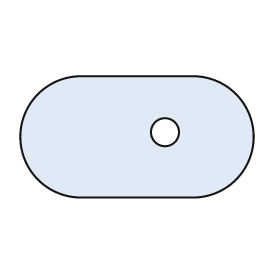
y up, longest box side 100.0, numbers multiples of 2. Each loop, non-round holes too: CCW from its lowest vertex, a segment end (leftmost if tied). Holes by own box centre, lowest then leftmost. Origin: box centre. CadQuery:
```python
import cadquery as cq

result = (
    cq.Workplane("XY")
    .moveTo(-24.0, -26.0)
    .lineTo(24.0, -26.0)
    .threePointArc((50.0, 0.0), (24.0, 26.0))
    .lineTo(-24.0, 26.0)
    .threePointArc((-50.0, 0.0), (-24.0, -26.0))
    .close()
    .moveTo(12.0, 2.0)
    .circle(6.0)
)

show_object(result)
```